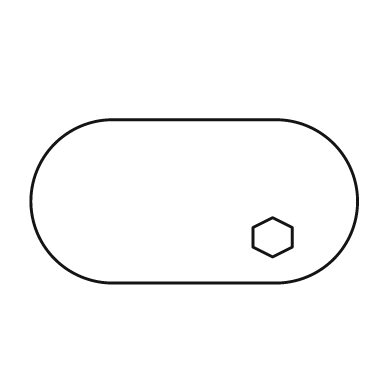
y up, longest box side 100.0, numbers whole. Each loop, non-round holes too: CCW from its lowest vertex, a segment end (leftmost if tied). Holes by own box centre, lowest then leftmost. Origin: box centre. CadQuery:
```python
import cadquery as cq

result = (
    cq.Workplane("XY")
    .moveTo(-25.0, -25.0)
    .lineTo(25.0, -25.0)
    .threePointArc((50.0, 0.0), (25.0, 25.0))
    .lineTo(-25.0, 25.0)
    .threePointArc((-50.0, 0.0), (-25.0, -25.0))
    .close()
    .moveTo(24.0, -17.0)
    .lineTo(30.0, -14.0)
    .lineTo(30.0, -8.0)
    .lineTo(24.0, -5.0)
    .lineTo(18.0, -8.0)
    .lineTo(18.0, -14.0)
    .close()
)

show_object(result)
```